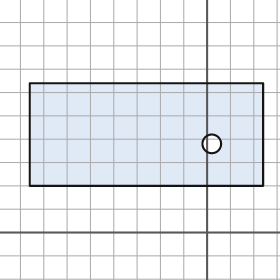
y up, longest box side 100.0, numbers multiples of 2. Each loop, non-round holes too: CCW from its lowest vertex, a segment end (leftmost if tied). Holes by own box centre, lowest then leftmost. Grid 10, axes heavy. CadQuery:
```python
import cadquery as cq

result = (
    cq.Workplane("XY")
    .moveTo(-76.0, 20.0)
    .lineTo(24.0, 20.0)
    .lineTo(24.0, 64.0)
    .lineTo(-76.0, 64.0)
    .close()
    .moveTo(2.0, 38.0)
    .circle(4.0)
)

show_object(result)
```